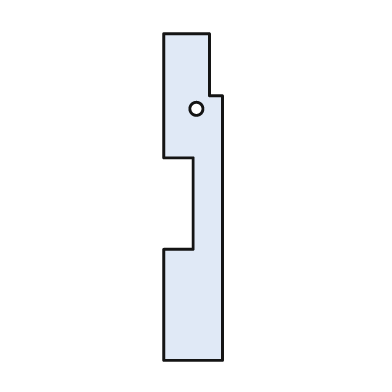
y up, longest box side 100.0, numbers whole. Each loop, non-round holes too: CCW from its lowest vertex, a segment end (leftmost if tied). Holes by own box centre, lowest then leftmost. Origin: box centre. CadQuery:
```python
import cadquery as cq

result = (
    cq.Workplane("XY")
    .moveTo(-9.0, -50.0)
    .lineTo(9.0, -50.0)
    .lineTo(9.0, 31.0)
    .lineTo(5.0, 31.0)
    .lineTo(5.0, 50.0)
    .lineTo(-9.0, 50.0)
    .lineTo(-9.0, 12.0)
    .lineTo(0.0, 12.0)
    .lineTo(0.0, -16.0)
    .lineTo(-9.0, -16.0)
    .close()
    .moveTo(1.0, 27.0)
    .circle(2.0)
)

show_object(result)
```